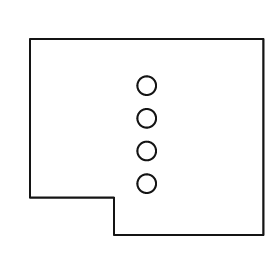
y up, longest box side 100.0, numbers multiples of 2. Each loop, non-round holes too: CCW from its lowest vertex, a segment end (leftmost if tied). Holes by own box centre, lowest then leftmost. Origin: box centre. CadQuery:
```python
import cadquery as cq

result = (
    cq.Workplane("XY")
    .moveTo(-14.0, -42.0)
    .lineTo(50.0, -42.0)
    .lineTo(50.0, 42.0)
    .lineTo(-50.0, 42.0)
    .lineTo(-50.0, -26.0)
    .lineTo(-14.0, -26.0)
    .close()
    .moveTo(0.0, -20.0)
    .circle(4.0)
    .moveTo(0.0, -6.0)
    .circle(4.0)
    .moveTo(0.0, 8.0)
    .circle(4.0)
    .moveTo(0.0, 22.0)
    .circle(4.0)
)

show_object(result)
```